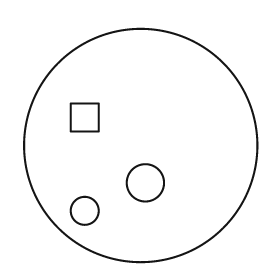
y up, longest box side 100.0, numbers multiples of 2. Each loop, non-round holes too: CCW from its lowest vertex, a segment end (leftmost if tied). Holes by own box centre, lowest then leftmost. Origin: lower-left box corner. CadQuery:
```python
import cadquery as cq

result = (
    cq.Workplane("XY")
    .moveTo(50.0, 50.0)
    .circle(50.0)
    .moveTo(26.0, 22.0)
    .circle(6.0)
    .moveTo(52.0, 34.0)
    .circle(8.0)
    .moveTo(20.0, 56.0)
    .lineTo(32.0, 56.0)
    .lineTo(32.0, 68.0)
    .lineTo(20.0, 68.0)
    .close()
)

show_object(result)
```